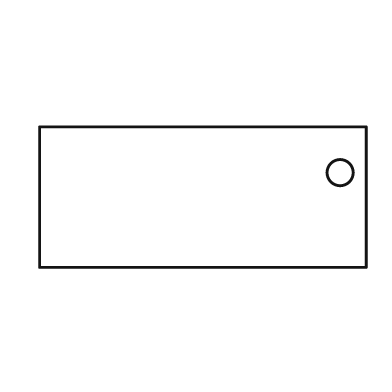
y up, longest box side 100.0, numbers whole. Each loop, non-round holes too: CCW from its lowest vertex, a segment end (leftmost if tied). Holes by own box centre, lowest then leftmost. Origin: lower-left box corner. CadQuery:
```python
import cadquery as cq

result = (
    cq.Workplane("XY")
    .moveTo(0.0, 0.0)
    .lineTo(100.0, 0.0)
    .lineTo(100.0, 43.0)
    .lineTo(0.0, 43.0)
    .close()
    .moveTo(92.0, 29.0)
    .circle(4.0)
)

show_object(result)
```